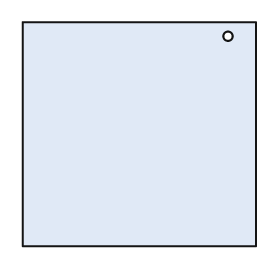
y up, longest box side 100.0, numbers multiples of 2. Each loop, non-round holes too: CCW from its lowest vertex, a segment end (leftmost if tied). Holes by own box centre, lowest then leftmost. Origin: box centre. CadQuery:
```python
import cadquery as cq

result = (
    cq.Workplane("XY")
    .moveTo(-50.0, -48.0)
    .lineTo(50.0, -48.0)
    .lineTo(50.0, 48.0)
    .lineTo(-50.0, 48.0)
    .close()
    .moveTo(38.0, 42.0)
    .circle(2.0)
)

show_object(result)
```